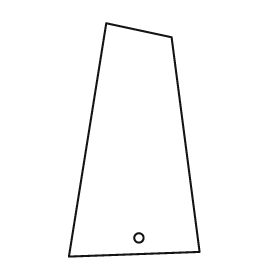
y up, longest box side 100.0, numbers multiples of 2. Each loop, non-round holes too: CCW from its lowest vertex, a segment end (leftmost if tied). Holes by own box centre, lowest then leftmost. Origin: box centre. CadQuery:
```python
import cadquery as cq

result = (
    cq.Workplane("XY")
    .moveTo(-28.0, -50.0)
    .lineTo(28.0, -48.0)
    .lineTo(16.0, 44.0)
    .lineTo(-12.0, 50.0)
    .close()
    .moveTo(2.0, -42.0)
    .circle(2.0)
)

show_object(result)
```